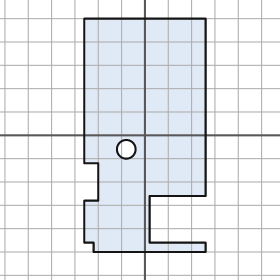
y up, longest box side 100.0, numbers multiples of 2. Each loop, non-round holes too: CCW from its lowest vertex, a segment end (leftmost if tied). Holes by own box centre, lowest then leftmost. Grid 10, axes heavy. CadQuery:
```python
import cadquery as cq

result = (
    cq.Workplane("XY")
    .moveTo(-22.0, -50.0)
    .lineTo(26.0, -50.0)
    .lineTo(26.0, -46.0)
    .lineTo(2.0, -46.0)
    .lineTo(2.0, -26.0)
    .lineTo(26.0, -26.0)
    .lineTo(26.0, 50.0)
    .lineTo(-26.0, 50.0)
    .lineTo(-26.0, -12.0)
    .lineTo(-20.0, -12.0)
    .lineTo(-20.0, -28.0)
    .lineTo(-26.0, -28.0)
    .lineTo(-26.0, -46.0)
    .lineTo(-22.0, -46.0)
    .close()
    .moveTo(-8.0, -6.0)
    .circle(4.0)
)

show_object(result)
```